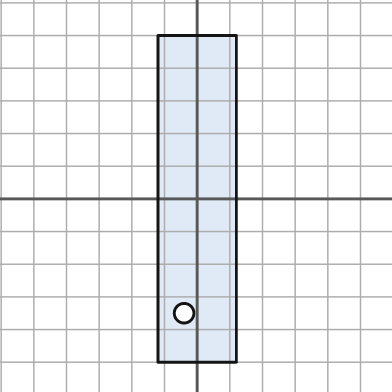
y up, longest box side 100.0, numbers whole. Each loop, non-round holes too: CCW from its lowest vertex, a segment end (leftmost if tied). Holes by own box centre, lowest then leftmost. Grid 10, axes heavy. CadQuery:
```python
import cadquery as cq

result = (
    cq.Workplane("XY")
    .moveTo(-12.0, -50.0)
    .lineTo(12.0, -50.0)
    .lineTo(12.0, 50.0)
    .lineTo(-12.0, 50.0)
    .close()
    .moveTo(-4.0, -35.0)
    .circle(3.0)
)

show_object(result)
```